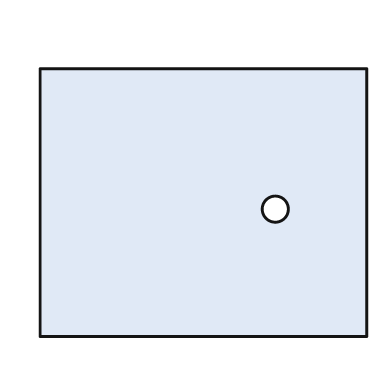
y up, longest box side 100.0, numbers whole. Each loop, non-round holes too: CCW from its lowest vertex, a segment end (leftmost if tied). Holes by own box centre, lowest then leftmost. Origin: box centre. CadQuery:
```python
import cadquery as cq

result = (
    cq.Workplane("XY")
    .moveTo(-50.0, -41.0)
    .lineTo(50.0, -41.0)
    .lineTo(50.0, 41.0)
    .lineTo(-50.0, 41.0)
    .close()
    .moveTo(22.0, -2.0)
    .circle(4.0)
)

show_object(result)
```